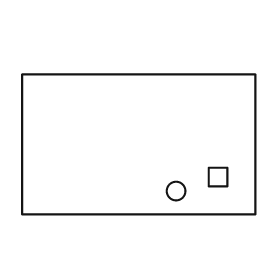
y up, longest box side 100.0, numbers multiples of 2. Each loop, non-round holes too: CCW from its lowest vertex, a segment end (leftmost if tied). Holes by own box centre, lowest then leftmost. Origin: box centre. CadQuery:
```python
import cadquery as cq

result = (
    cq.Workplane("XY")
    .moveTo(-50.0, -30.0)
    .lineTo(50.0, -30.0)
    .lineTo(50.0, 30.0)
    .lineTo(-50.0, 30.0)
    .close()
    .moveTo(16.0, -20.0)
    .circle(4.0)
    .moveTo(30.0, -18.0)
    .lineTo(38.0, -18.0)
    .lineTo(38.0, -10.0)
    .lineTo(30.0, -10.0)
    .close()
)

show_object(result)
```